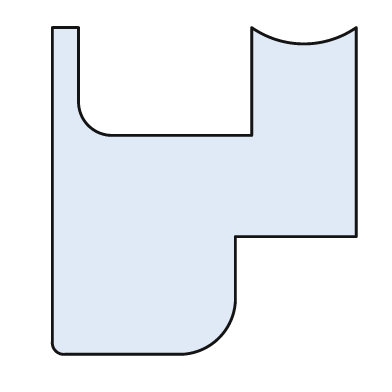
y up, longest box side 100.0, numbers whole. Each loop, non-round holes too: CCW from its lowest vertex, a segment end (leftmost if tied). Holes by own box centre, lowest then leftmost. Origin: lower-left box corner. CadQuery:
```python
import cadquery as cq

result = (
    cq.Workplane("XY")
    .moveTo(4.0, 0.0)
    .lineTo(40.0, 0.0)
    .threePointArc((51.0, 5.0), (56.0, 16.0))
    .lineTo(56.0, 36.0)
    .lineTo(93.0, 36.0)
    .lineTo(93.0, 100.0)
    .threePointArc((77.0, 95.0), (61.0, 100.0))
    .lineTo(61.0, 67.0)
    .lineTo(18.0, 67.0)
    .threePointArc((11.0, 70.0), (8.0, 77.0))
    .lineTo(8.0, 100.0)
    .lineTo(0.0, 100.0)
    .lineTo(0.0, 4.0)
    .threePointArc((1.0, 1.0), (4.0, 0.0))
    .close()
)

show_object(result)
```